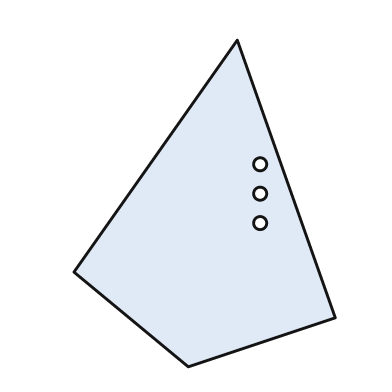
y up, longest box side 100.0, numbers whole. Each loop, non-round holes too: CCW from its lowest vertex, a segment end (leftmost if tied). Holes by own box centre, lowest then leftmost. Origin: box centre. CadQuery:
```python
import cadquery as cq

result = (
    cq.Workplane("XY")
    .moveTo(-5.0, -50.0)
    .lineTo(40.0, -35.0)
    .lineTo(10.0, 50.0)
    .lineTo(-40.0, -21.0)
    .close()
    .moveTo(17.0, -6.0)
    .circle(2.0)
    .moveTo(17.0, 3.0)
    .circle(2.0)
    .moveTo(17.0, 12.0)
    .circle(2.0)
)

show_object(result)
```